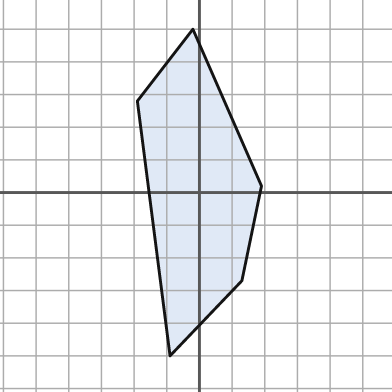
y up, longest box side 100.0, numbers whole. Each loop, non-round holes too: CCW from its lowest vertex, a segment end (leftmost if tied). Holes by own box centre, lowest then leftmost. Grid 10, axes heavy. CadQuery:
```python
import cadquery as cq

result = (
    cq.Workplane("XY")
    .moveTo(-9.0, -50.0)
    .lineTo(13.0, -27.0)
    .lineTo(19.0, 2.0)
    .lineTo(-2.0, 50.0)
    .lineTo(-19.0, 28.0)
    .close()
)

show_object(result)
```